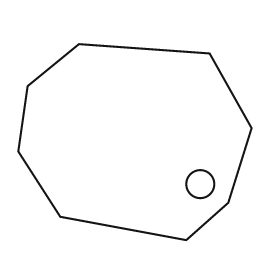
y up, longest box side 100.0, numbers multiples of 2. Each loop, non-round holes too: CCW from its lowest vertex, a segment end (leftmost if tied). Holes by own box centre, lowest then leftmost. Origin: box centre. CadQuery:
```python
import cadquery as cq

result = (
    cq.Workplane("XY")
    .moveTo(22.0, -42.0)
    .lineTo(40.0, -26.0)
    .lineTo(50.0, 6.0)
    .lineTo(32.0, 38.0)
    .lineTo(-24.0, 42.0)
    .lineTo(-46.0, 24.0)
    .lineTo(-50.0, -4.0)
    .lineTo(-32.0, -32.0)
    .close()
    .moveTo(28.0, -18.0)
    .circle(6.0)
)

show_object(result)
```